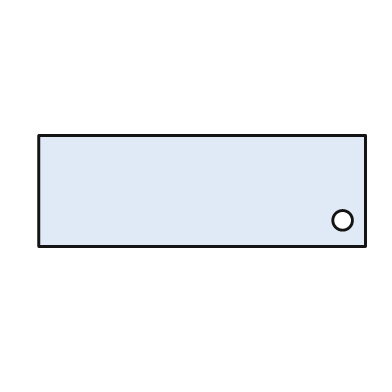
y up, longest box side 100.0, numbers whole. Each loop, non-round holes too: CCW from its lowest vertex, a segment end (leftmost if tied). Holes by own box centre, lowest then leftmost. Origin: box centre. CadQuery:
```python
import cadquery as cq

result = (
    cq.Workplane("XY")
    .moveTo(-50.0, -17.0)
    .lineTo(50.0, -17.0)
    .lineTo(50.0, 17.0)
    .lineTo(-50.0, 17.0)
    .close()
    .moveTo(43.0, -9.0)
    .circle(3.0)
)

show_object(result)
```